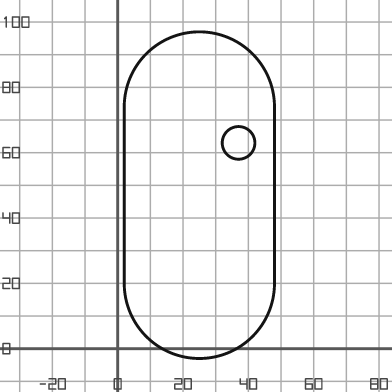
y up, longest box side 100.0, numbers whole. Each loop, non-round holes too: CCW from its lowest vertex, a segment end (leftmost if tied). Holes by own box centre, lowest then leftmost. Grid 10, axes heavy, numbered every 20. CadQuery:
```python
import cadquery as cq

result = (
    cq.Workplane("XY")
    .moveTo(2.0, 20.0)
    .threePointArc((25.0, -3.0), (48.0, 20.0))
    .lineTo(48.0, 74.0)
    .threePointArc((25.0, 97.0), (2.0, 74.0))
    .close()
    .moveTo(37.0, 63.0)
    .circle(5.0)
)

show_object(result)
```